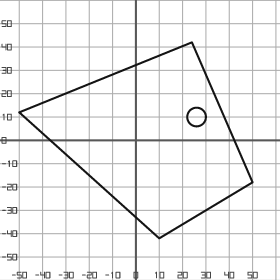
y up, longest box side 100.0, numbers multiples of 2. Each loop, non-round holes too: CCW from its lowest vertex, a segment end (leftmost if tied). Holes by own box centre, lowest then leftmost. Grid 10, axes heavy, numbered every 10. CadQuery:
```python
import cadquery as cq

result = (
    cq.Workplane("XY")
    .moveTo(10.0, -42.0)
    .lineTo(50.0, -18.0)
    .lineTo(24.0, 42.0)
    .lineTo(-50.0, 12.0)
    .close()
    .moveTo(26.0, 10.0)
    .circle(4.0)
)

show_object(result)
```